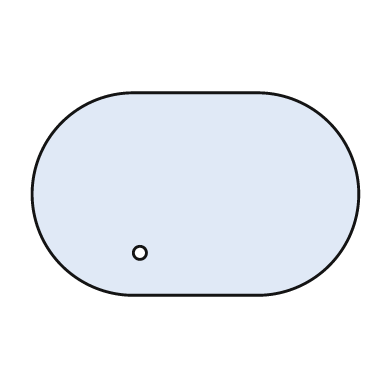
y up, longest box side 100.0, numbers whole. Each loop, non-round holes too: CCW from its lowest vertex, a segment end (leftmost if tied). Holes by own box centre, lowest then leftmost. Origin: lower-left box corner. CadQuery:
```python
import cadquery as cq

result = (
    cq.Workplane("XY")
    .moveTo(31.0, 0.0)
    .lineTo(69.0, 0.0)
    .threePointArc((100.0, 31.0), (69.0, 62.0))
    .lineTo(31.0, 62.0)
    .threePointArc((0.0, 31.0), (31.0, 0.0))
    .close()
    .moveTo(33.0, 13.0)
    .circle(2.0)
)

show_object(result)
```